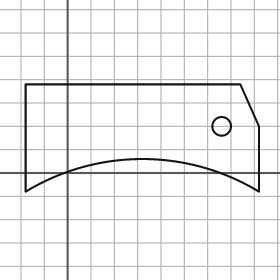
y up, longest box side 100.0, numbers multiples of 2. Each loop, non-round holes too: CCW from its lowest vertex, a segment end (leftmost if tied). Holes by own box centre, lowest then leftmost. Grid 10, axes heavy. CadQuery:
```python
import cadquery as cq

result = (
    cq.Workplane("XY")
    .moveTo(-18.0, -8.0)
    .threePointArc((32.0, 6.0), (82.0, -8.0))
    .lineTo(82.0, 20.0)
    .lineTo(74.0, 38.0)
    .lineTo(-18.0, 38.0)
    .close()
    .moveTo(66.0, 20.0)
    .circle(4.0)
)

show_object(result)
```